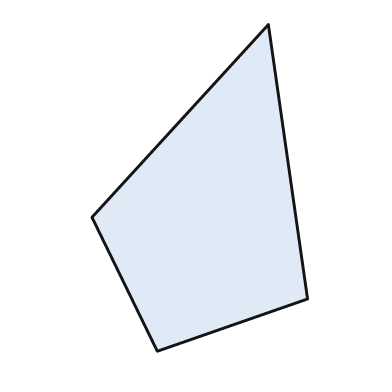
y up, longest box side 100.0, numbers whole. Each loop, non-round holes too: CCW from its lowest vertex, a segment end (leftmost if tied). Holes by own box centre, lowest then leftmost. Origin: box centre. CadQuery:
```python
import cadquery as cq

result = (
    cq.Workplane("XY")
    .moveTo(-13.0, -50.0)
    .lineTo(33.0, -34.0)
    .lineTo(21.0, 50.0)
    .lineTo(-33.0, -9.0)
    .close()
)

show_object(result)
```